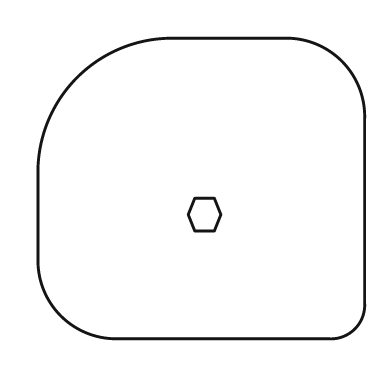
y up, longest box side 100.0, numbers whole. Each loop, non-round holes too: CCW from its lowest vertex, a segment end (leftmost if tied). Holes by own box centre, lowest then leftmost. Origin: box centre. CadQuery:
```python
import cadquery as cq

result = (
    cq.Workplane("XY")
    .moveTo(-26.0, -46.0)
    .lineTo(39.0, -46.0)
    .threePointArc((47.0, -43.0), (50.0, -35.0))
    .lineTo(50.0, 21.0)
    .threePointArc((43.0, 39.0), (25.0, 46.0))
    .lineTo(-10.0, 46.0)
    .threePointArc((-38.0, 34.0), (-50.0, 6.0))
    .lineTo(-50.0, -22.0)
    .threePointArc((-43.0, -39.0), (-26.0, -46.0))
    .close()
    .moveTo(-2.0, -13.0)
    .lineTo(4.0, -13.0)
    .lineTo(6.0, -8.0)
    .lineTo(4.0, -3.0)
    .lineTo(-2.0, -3.0)
    .lineTo(-4.0, -8.0)
    .close()
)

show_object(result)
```